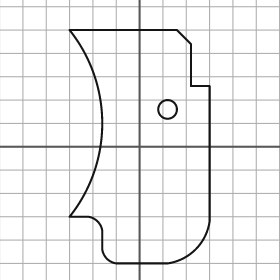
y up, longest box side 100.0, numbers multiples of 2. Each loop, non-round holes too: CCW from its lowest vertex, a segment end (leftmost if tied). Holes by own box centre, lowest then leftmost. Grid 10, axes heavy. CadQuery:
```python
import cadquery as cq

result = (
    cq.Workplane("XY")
    .moveTo(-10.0, -50.0)
    .lineTo(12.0, -50.0)
    .threePointArc((24.0, -44.0), (30.0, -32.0))
    .lineTo(30.0, 26.0)
    .lineTo(22.0, 26.0)
    .lineTo(22.0, 44.0)
    .lineTo(16.0, 50.0)
    .lineTo(-30.0, 50.0)
    .threePointArc((-16.0, 10.0), (-30.0, -30.0))
    .lineTo(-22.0, -30.0)
    .threePointArc((-18.0, -32.0), (-16.0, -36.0))
    .lineTo(-16.0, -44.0)
    .threePointArc((-14.0, -48.0), (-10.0, -50.0))
    .close()
    .moveTo(12.0, 16.0)
    .circle(4.0)
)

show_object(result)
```